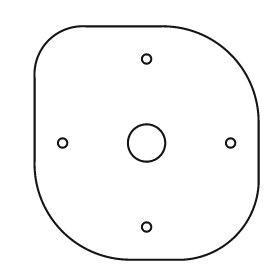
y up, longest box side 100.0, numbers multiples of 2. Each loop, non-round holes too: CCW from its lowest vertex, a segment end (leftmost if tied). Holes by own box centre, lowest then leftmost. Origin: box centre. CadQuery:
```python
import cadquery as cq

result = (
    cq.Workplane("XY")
    .moveTo(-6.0, -50.0)
    .lineTo(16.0, -50.0)
    .threePointArc((38.0, -40.0), (48.0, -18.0))
    .lineTo(48.0, 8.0)
    .threePointArc((36.0, 38.0), (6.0, 50.0))
    .lineTo(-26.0, 50.0)
    .threePointArc((-42.0, 44.0), (-48.0, 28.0))
    .lineTo(-48.0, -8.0)
    .threePointArc((-36.0, -38.0), (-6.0, -50.0))
    .close()
    .moveTo(0.0, -36.0)
    .circle(2.0)
    .moveTo(-36.0, 0.0)
    .circle(2.0)
    .moveTo(0.0, 0.0)
    .circle(8.0)
    .moveTo(36.0, 0.0)
    .circle(2.0)
    .moveTo(0.0, 36.0)
    .circle(2.0)
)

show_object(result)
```